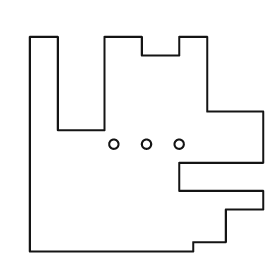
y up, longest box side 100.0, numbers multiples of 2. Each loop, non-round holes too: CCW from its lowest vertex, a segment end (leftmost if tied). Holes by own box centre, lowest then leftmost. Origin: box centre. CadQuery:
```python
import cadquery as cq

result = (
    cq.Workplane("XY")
    .moveTo(-50.0, -46.0)
    .lineTo(20.0, -46.0)
    .lineTo(20.0, -42.0)
    .lineTo(34.0, -42.0)
    .lineTo(34.0, -28.0)
    .lineTo(50.0, -28.0)
    .lineTo(50.0, -20.0)
    .lineTo(14.0, -20.0)
    .lineTo(14.0, -8.0)
    .lineTo(50.0, -8.0)
    .lineTo(50.0, 14.0)
    .lineTo(26.0, 14.0)
    .lineTo(26.0, 46.0)
    .lineTo(14.0, 46.0)
    .lineTo(14.0, 38.0)
    .lineTo(-2.0, 38.0)
    .lineTo(-2.0, 46.0)
    .lineTo(-18.0, 46.0)
    .lineTo(-18.0, 6.0)
    .lineTo(-38.0, 6.0)
    .lineTo(-38.0, 46.0)
    .lineTo(-50.0, 46.0)
    .close()
    .moveTo(-14.0, 0.0)
    .circle(2.0)
    .moveTo(0.0, 0.0)
    .circle(2.0)
    .moveTo(14.0, 0.0)
    .circle(2.0)
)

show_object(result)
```